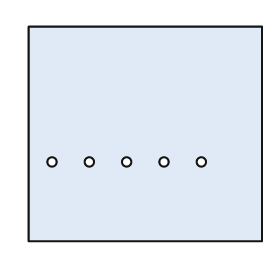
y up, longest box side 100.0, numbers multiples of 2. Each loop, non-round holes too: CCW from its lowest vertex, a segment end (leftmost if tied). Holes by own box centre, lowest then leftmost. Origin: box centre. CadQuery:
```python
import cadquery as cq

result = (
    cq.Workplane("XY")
    .moveTo(-50.0, -46.0)
    .lineTo(50.0, -46.0)
    .lineTo(50.0, 46.0)
    .lineTo(-50.0, 46.0)
    .close()
    .moveTo(-40.0, -12.0)
    .circle(2.0)
    .moveTo(-24.0, -12.0)
    .circle(2.0)
    .moveTo(-8.0, -12.0)
    .circle(2.0)
    .moveTo(8.0, -12.0)
    .circle(2.0)
    .moveTo(24.0, -12.0)
    .circle(2.0)
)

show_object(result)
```